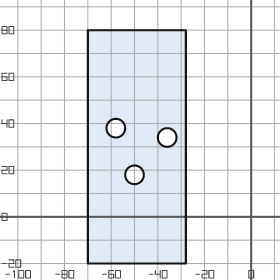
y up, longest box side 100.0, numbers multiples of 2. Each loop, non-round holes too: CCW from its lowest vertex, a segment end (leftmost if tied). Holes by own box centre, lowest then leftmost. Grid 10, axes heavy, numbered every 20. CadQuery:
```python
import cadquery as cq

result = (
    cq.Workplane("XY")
    .moveTo(-70.0, -20.0)
    .lineTo(-28.0, -20.0)
    .lineTo(-28.0, 80.0)
    .lineTo(-70.0, 80.0)
    .close()
    .moveTo(-50.0, 18.0)
    .circle(4.0)
    .moveTo(-36.0, 34.0)
    .circle(4.0)
    .moveTo(-58.0, 38.0)
    .circle(4.0)
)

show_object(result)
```